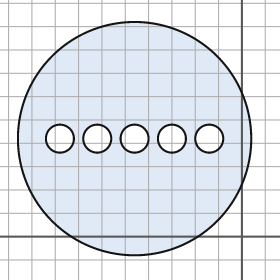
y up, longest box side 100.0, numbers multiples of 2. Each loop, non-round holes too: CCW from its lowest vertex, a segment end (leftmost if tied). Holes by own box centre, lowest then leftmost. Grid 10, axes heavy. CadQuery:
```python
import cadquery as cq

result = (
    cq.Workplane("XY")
    .moveTo(-46.0, 42.0)
    .circle(50.0)
    .moveTo(-78.0, 42.0)
    .circle(6.0)
    .moveTo(-62.0, 42.0)
    .circle(6.0)
    .moveTo(-46.0, 42.0)
    .circle(6.0)
    .moveTo(-30.0, 42.0)
    .circle(6.0)
    .moveTo(-14.0, 42.0)
    .circle(6.0)
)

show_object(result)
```